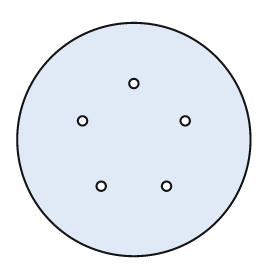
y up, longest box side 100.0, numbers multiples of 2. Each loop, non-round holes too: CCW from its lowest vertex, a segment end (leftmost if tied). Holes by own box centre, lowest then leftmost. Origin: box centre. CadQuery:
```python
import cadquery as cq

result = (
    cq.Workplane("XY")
    .moveTo(0.0, 0.0)
    .circle(50.0)
    .moveTo(-14.0, -20.0)
    .circle(2.0)
    .moveTo(14.0, -20.0)
    .circle(2.0)
    .moveTo(-22.0, 8.0)
    .circle(2.0)
    .moveTo(22.0, 8.0)
    .circle(2.0)
    .moveTo(0.0, 24.0)
    .circle(2.0)
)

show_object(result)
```